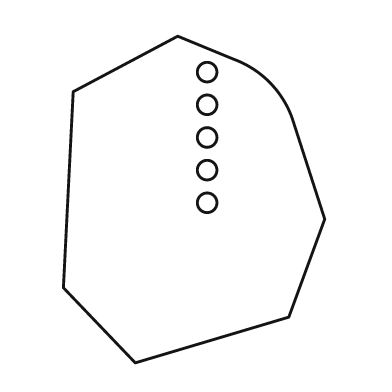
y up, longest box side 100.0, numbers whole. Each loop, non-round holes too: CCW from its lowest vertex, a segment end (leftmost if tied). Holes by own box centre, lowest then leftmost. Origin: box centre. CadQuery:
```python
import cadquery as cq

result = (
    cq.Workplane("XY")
    .moveTo(-18.0, -50.0)
    .lineTo(29.0, -36.0)
    .lineTo(40.0, -6.0)
    .lineTo(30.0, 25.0)
    .threePointArc((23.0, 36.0), (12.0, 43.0))
    .lineTo(-5.0, 50.0)
    .lineTo(-37.0, 33.0)
    .lineTo(-40.0, -27.0)
    .close()
    .moveTo(4.0, -1.0)
    .circle(3.0)
    .moveTo(4.0, 9.0)
    .circle(3.0)
    .moveTo(4.0, 19.0)
    .circle(3.0)
    .moveTo(4.0, 29.0)
    .circle(3.0)
    .moveTo(4.0, 39.0)
    .circle(3.0)
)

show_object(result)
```